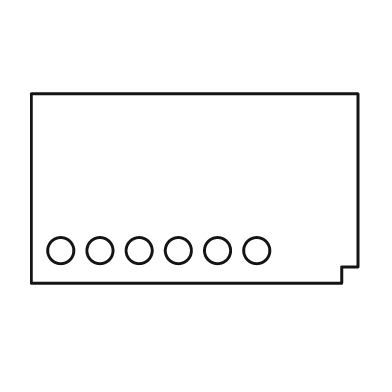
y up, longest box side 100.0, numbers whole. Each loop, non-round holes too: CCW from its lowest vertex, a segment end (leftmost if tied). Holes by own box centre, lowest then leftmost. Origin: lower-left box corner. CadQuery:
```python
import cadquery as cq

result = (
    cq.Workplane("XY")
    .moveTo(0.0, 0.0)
    .lineTo(95.0, 0.0)
    .lineTo(95.0, 5.0)
    .lineTo(100.0, 5.0)
    .lineTo(100.0, 58.0)
    .lineTo(0.0, 58.0)
    .close()
    .moveTo(9.0, 10.0)
    .circle(4.0)
    .moveTo(21.0, 10.0)
    .circle(4.0)
    .moveTo(33.0, 10.0)
    .circle(4.0)
    .moveTo(45.0, 10.0)
    .circle(4.0)
    .moveTo(57.0, 10.0)
    .circle(4.0)
    .moveTo(69.0, 10.0)
    .circle(4.0)
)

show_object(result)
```